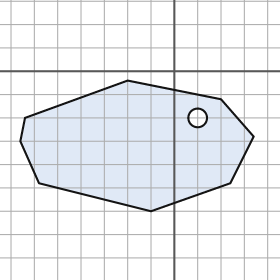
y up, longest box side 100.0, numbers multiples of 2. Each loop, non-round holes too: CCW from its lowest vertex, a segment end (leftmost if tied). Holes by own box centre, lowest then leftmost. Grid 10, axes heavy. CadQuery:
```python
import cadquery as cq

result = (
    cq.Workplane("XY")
    .moveTo(-10.0, -60.0)
    .lineTo(24.0, -48.0)
    .lineTo(34.0, -28.0)
    .lineTo(20.0, -12.0)
    .lineTo(-20.0, -4.0)
    .lineTo(-64.0, -20.0)
    .lineTo(-66.0, -30.0)
    .lineTo(-58.0, -48.0)
    .close()
    .moveTo(10.0, -20.0)
    .circle(4.0)
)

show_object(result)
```